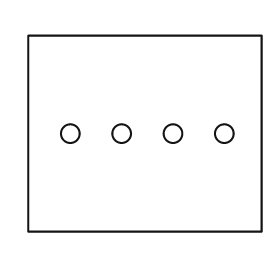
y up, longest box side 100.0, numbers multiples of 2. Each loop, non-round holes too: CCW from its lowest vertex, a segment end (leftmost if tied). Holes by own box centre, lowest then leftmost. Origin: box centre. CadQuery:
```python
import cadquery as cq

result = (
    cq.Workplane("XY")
    .moveTo(-50.0, -42.0)
    .lineTo(50.0, -42.0)
    .lineTo(50.0, 42.0)
    .lineTo(-50.0, 42.0)
    .close()
    .moveTo(-32.0, 0.0)
    .circle(4.0)
    .moveTo(-10.0, 0.0)
    .circle(4.0)
    .moveTo(12.0, 0.0)
    .circle(4.0)
    .moveTo(34.0, 0.0)
    .circle(4.0)
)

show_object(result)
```